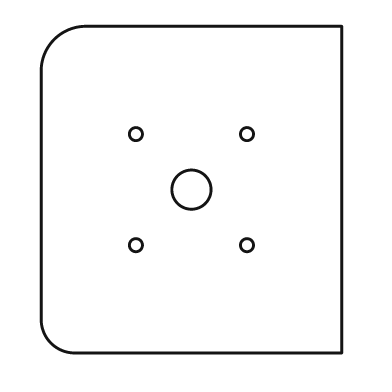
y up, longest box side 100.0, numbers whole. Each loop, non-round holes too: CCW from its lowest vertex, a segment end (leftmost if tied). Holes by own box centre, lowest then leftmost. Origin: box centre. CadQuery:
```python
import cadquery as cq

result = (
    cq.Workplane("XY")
    .moveTo(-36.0, -50.0)
    .lineTo(46.0, -50.0)
    .lineTo(46.0, 50.0)
    .lineTo(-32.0, 50.0)
    .threePointArc((-42.0, 46.0), (-46.0, 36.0))
    .lineTo(-46.0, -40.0)
    .threePointArc((-43.0, -47.0), (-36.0, -50.0))
    .close()
    .moveTo(-17.0, -17.0)
    .circle(2.0)
    .moveTo(17.0, -17.0)
    .circle(2.0)
    .moveTo(0.0, 0.0)
    .circle(6.0)
    .moveTo(-17.0, 17.0)
    .circle(2.0)
    .moveTo(17.0, 17.0)
    .circle(2.0)
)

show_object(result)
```